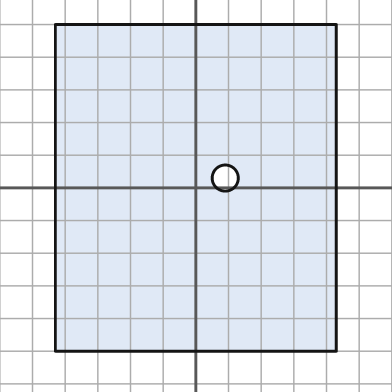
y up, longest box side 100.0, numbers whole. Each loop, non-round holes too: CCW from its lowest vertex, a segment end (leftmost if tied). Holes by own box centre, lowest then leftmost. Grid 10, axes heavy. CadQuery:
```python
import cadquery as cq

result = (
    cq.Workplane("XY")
    .moveTo(-43.0, -50.0)
    .lineTo(43.0, -50.0)
    .lineTo(43.0, 50.0)
    .lineTo(-43.0, 50.0)
    .close()
    .moveTo(9.0, 3.0)
    .circle(4.0)
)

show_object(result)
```